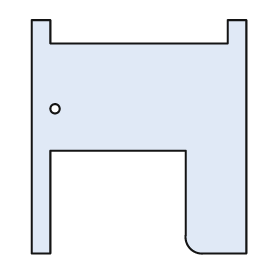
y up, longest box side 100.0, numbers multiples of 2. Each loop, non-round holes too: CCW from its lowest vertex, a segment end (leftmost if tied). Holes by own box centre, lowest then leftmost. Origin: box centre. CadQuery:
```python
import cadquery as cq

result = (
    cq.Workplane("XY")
    .moveTo(-46.0, -50.0)
    .lineTo(-38.0, -50.0)
    .lineTo(-38.0, -6.0)
    .lineTo(20.0, -6.0)
    .lineTo(20.0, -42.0)
    .threePointArc((22.0, -48.0), (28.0, -50.0))
    .lineTo(46.0, -50.0)
    .lineTo(46.0, 50.0)
    .lineTo(38.0, 50.0)
    .lineTo(38.0, 40.0)
    .lineTo(-38.0, 40.0)
    .lineTo(-38.0, 50.0)
    .lineTo(-46.0, 50.0)
    .close()
    .moveTo(-36.0, 12.0)
    .circle(2.0)
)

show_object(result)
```